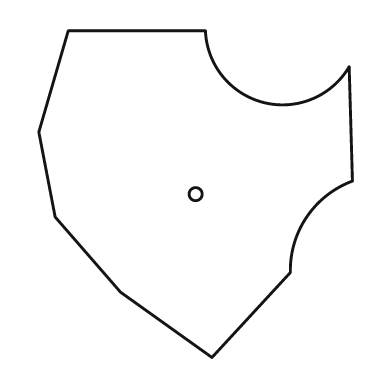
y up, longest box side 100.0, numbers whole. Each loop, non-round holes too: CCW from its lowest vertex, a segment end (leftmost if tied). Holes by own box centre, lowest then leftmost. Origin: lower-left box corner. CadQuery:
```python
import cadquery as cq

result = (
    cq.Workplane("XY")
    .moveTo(53.0, 0.0)
    .lineTo(77.0, 26.0)
    .threePointArc((82.0, 43.0), (96.0, 54.0))
    .lineTo(95.0, 89.0)
    .threePointArc((69.0, 78.0), (51.0, 100.0))
    .lineTo(9.0, 100.0)
    .lineTo(0.0, 69.0)
    .lineTo(5.0, 43.0)
    .lineTo(25.0, 20.0)
    .close()
    .moveTo(48.0, 50.0)
    .circle(2.0)
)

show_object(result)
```